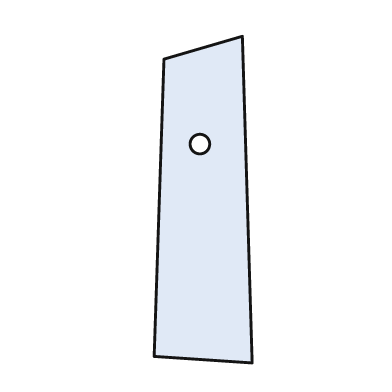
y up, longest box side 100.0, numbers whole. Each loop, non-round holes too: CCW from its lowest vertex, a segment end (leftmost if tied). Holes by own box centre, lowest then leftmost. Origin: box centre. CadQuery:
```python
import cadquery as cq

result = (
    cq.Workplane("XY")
    .moveTo(15.0, -50.0)
    .lineTo(12.0, 50.0)
    .lineTo(-12.0, 43.0)
    .lineTo(-15.0, -48.0)
    .close()
    .moveTo(-1.0, 17.0)
    .circle(3.0)
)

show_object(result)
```